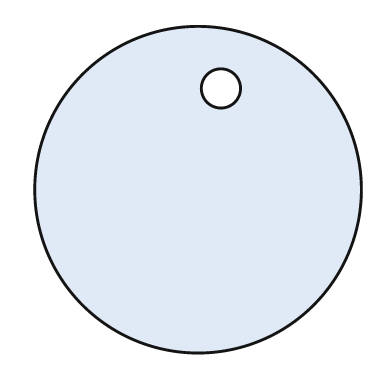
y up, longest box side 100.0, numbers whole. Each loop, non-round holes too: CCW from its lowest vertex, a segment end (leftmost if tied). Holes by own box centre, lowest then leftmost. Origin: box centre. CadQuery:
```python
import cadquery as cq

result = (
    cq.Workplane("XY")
    .moveTo(0.0, 0.0)
    .circle(50.0)
    .moveTo(7.0, 31.0)
    .circle(6.0)
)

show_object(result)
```